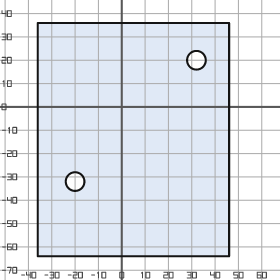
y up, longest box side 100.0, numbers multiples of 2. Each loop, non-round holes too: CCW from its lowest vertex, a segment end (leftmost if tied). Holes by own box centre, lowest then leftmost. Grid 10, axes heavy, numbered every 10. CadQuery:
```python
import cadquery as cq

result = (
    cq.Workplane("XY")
    .moveTo(-36.0, -64.0)
    .lineTo(46.0, -64.0)
    .lineTo(46.0, 36.0)
    .lineTo(-36.0, 36.0)
    .close()
    .moveTo(-20.0, -32.0)
    .circle(4.0)
    .moveTo(32.0, 20.0)
    .circle(4.0)
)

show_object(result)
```